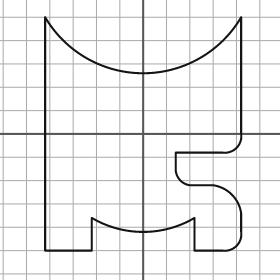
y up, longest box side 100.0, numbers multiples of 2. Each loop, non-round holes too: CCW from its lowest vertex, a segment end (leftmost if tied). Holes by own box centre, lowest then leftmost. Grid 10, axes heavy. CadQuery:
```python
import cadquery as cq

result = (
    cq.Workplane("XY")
    .moveTo(-42.0, -50.0)
    .lineTo(-22.0, -50.0)
    .lineTo(-22.0, -36.0)
    .threePointArc((0.0, -42.0), (22.0, -36.0))
    .lineTo(22.0, -50.0)
    .lineTo(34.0, -50.0)
    .threePointArc((40.0, -48.0), (42.0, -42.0))
    .lineTo(42.0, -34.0)
    .threePointArc((38.0, -26.0), (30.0, -22.0))
    .lineTo(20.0, -22.0)
    .threePointArc((16.0, -20.0), (14.0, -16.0))
    .lineTo(14.0, -8.0)
    .lineTo(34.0, -8.0)
    .threePointArc((40.0, -6.0), (42.0, 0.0))
    .lineTo(42.0, 50.0)
    .threePointArc((0.0, 26.0), (-42.0, 50.0))
    .close()
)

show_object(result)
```